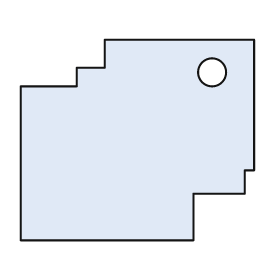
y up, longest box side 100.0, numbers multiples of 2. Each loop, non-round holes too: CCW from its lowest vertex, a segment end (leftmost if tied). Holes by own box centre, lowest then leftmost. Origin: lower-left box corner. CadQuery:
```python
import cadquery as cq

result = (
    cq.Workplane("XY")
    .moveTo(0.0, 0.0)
    .lineTo(74.0, 0.0)
    .lineTo(74.0, 20.0)
    .lineTo(96.0, 20.0)
    .lineTo(96.0, 30.0)
    .lineTo(100.0, 30.0)
    .lineTo(100.0, 86.0)
    .lineTo(36.0, 86.0)
    .lineTo(36.0, 74.0)
    .lineTo(24.0, 74.0)
    .lineTo(24.0, 66.0)
    .lineTo(0.0, 66.0)
    .close()
    .moveTo(82.0, 72.0)
    .circle(6.0)
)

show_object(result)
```